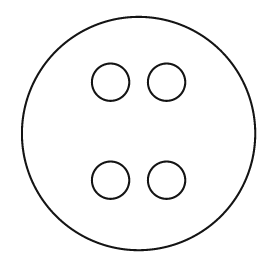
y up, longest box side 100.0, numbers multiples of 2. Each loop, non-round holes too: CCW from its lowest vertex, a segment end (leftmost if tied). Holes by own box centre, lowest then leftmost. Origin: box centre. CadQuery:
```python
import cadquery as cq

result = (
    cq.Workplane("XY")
    .moveTo(0.0, 0.0)
    .circle(50.0)
    .moveTo(-12.0, -20.0)
    .circle(8.0)
    .moveTo(12.0, -20.0)
    .circle(8.0)
    .moveTo(-12.0, 22.0)
    .circle(8.0)
    .moveTo(12.0, 22.0)
    .circle(8.0)
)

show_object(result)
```